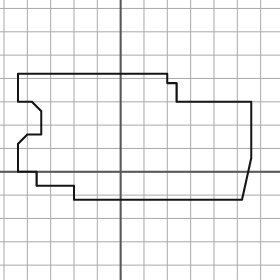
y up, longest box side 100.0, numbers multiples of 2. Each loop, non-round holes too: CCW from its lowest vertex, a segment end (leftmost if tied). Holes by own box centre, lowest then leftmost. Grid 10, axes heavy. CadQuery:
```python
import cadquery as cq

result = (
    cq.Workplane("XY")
    .moveTo(-20.0, -12.0)
    .lineTo(52.0, -12.0)
    .lineTo(56.0, 6.0)
    .lineTo(56.0, 30.0)
    .lineTo(24.0, 30.0)
    .lineTo(24.0, 38.0)
    .lineTo(20.0, 38.0)
    .lineTo(20.0, 42.0)
    .lineTo(-44.0, 42.0)
    .lineTo(-44.0, 30.0)
    .lineTo(-38.0, 30.0)
    .lineTo(-34.0, 26.0)
    .lineTo(-34.0, 16.0)
    .lineTo(-40.0, 16.0)
    .lineTo(-44.0, 12.0)
    .lineTo(-44.0, 0.0)
    .lineTo(-36.0, 0.0)
    .lineTo(-36.0, -6.0)
    .lineTo(-20.0, -6.0)
    .close()
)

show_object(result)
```